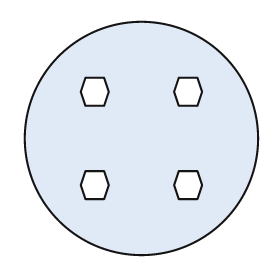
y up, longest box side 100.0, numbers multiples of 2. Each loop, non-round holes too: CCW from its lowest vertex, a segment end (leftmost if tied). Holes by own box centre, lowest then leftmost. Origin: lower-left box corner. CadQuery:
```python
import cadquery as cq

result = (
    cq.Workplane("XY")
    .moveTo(50.0, 50.0)
    .circle(50.0)
    .moveTo(26.0, 24.0)
    .lineTo(34.0, 24.0)
    .lineTo(36.0, 30.0)
    .lineTo(34.0, 36.0)
    .lineTo(26.0, 36.0)
    .lineTo(24.0, 30.0)
    .close()
    .moveTo(66.0, 24.0)
    .lineTo(74.0, 24.0)
    .lineTo(76.0, 30.0)
    .lineTo(74.0, 36.0)
    .lineTo(66.0, 36.0)
    .lineTo(64.0, 30.0)
    .close()
    .moveTo(26.0, 64.0)
    .lineTo(34.0, 64.0)
    .lineTo(36.0, 70.0)
    .lineTo(34.0, 76.0)
    .lineTo(26.0, 76.0)
    .lineTo(24.0, 70.0)
    .close()
    .moveTo(66.0, 64.0)
    .lineTo(74.0, 64.0)
    .lineTo(76.0, 70.0)
    .lineTo(74.0, 76.0)
    .lineTo(66.0, 76.0)
    .lineTo(64.0, 70.0)
    .close()
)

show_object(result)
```